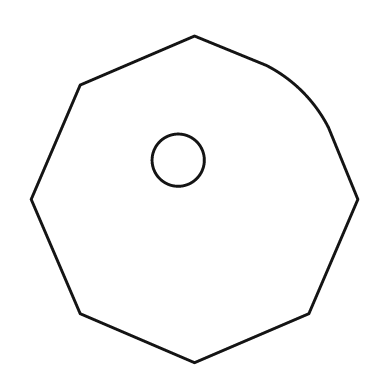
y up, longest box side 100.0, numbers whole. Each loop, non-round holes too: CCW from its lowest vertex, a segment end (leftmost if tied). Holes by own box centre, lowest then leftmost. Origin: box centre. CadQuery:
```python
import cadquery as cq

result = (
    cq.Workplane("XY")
    .moveTo(0.0, -50.0)
    .lineTo(35.0, -35.0)
    .lineTo(50.0, 0.0)
    .lineTo(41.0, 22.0)
    .threePointArc((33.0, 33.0), (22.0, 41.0))
    .lineTo(0.0, 50.0)
    .lineTo(-35.0, 35.0)
    .lineTo(-50.0, 0.0)
    .lineTo(-35.0, -35.0)
    .close()
    .moveTo(-5.0, 12.0)
    .circle(8.0)
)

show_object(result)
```